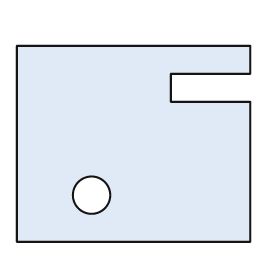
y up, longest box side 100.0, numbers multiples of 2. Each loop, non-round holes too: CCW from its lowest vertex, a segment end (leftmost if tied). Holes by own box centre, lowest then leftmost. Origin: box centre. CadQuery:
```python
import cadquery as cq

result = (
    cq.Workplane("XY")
    .moveTo(-50.0, -42.0)
    .lineTo(50.0, -42.0)
    .lineTo(50.0, 18.0)
    .lineTo(16.0, 18.0)
    .lineTo(16.0, 30.0)
    .lineTo(50.0, 30.0)
    .lineTo(50.0, 42.0)
    .lineTo(-50.0, 42.0)
    .close()
    .moveTo(-18.0, -22.0)
    .circle(8.0)
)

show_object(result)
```